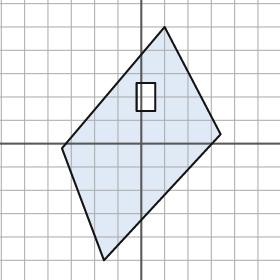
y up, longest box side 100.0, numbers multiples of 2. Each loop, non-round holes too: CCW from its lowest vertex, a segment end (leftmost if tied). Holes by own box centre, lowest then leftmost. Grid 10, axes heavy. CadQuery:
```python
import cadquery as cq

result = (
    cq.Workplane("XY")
    .moveTo(-16.0, -50.0)
    .lineTo(34.0, 4.0)
    .lineTo(10.0, 50.0)
    .lineTo(-34.0, -2.0)
    .close()
    .moveTo(-2.0, 14.0)
    .lineTo(6.0, 14.0)
    .lineTo(6.0, 26.0)
    .lineTo(-2.0, 26.0)
    .close()
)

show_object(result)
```